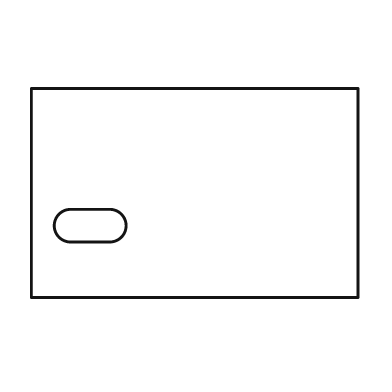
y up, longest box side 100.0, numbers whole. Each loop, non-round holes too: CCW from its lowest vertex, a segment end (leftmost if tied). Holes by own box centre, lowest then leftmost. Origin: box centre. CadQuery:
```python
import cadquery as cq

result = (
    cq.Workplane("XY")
    .moveTo(-50.0, -32.0)
    .lineTo(50.0, -32.0)
    .lineTo(50.0, 32.0)
    .lineTo(-50.0, 32.0)
    .close()
    .moveTo(-38.0, -15.0)
    .lineTo(-26.0, -15.0)
    .threePointArc((-21.0, -10.0), (-26.0, -5.0))
    .lineTo(-38.0, -5.0)
    .threePointArc((-43.0, -10.0), (-38.0, -15.0))
    .close()
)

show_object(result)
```